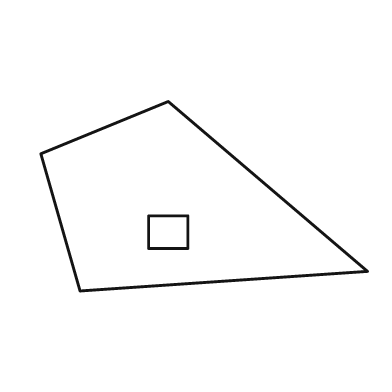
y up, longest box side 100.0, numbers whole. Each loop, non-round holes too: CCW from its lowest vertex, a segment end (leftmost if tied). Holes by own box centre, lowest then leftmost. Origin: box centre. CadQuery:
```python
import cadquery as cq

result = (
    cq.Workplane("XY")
    .moveTo(-38.0, -29.0)
    .lineTo(50.0, -23.0)
    .lineTo(-11.0, 29.0)
    .lineTo(-50.0, 13.0)
    .close()
    .moveTo(-17.0, -16.0)
    .lineTo(-5.0, -16.0)
    .lineTo(-5.0, -6.0)
    .lineTo(-17.0, -6.0)
    .close()
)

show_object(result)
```